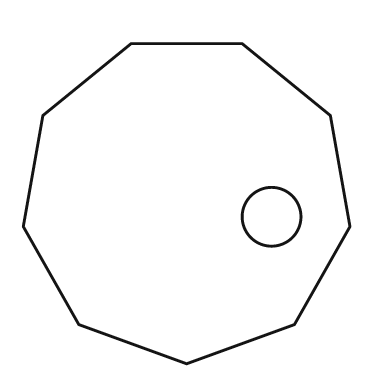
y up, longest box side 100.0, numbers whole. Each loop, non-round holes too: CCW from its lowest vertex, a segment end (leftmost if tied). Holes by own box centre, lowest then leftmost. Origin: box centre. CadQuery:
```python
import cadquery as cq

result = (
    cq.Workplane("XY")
    .moveTo(0.0, -49.0)
    .lineTo(33.0, -37.0)
    .lineTo(50.0, -7.0)
    .lineTo(44.0, 27.0)
    .lineTo(17.0, 49.0)
    .lineTo(-17.0, 49.0)
    .lineTo(-44.0, 27.0)
    .lineTo(-50.0, -7.0)
    .lineTo(-33.0, -37.0)
    .close()
    .moveTo(26.0, -4.0)
    .circle(9.0)
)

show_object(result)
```